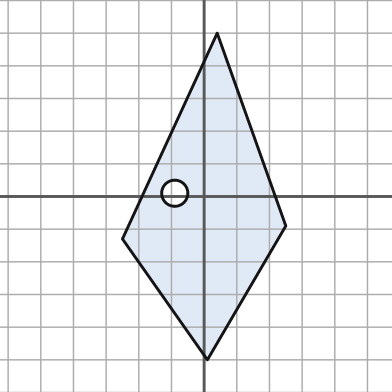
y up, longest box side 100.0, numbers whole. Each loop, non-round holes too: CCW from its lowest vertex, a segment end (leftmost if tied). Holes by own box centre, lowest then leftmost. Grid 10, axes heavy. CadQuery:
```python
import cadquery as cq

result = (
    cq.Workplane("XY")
    .moveTo(1.0, -50.0)
    .lineTo(25.0, -9.0)
    .lineTo(4.0, 50.0)
    .lineTo(-25.0, -13.0)
    .close()
    .moveTo(-9.0, 1.0)
    .circle(4.0)
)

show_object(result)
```